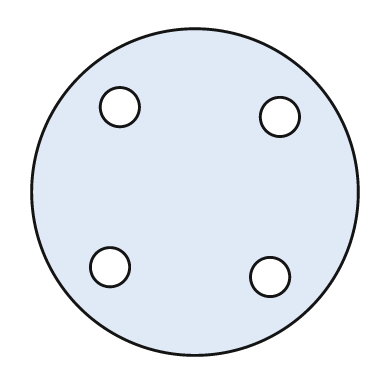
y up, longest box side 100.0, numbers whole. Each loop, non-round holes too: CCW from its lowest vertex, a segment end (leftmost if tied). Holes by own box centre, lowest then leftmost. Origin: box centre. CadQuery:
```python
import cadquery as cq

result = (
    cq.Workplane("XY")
    .moveTo(0.0, 0.0)
    .circle(50.0)
    .moveTo(23.0, -26.0)
    .circle(6.0)
    .moveTo(-26.0, -23.0)
    .circle(6.0)
    .moveTo(26.0, 23.0)
    .circle(6.0)
    .moveTo(-23.0, 26.0)
    .circle(6.0)
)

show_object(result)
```